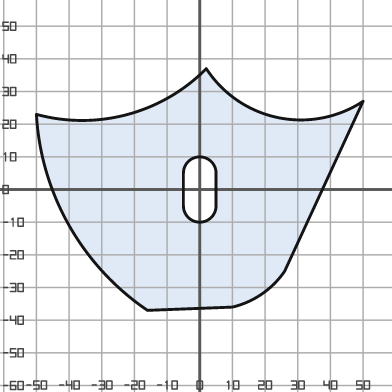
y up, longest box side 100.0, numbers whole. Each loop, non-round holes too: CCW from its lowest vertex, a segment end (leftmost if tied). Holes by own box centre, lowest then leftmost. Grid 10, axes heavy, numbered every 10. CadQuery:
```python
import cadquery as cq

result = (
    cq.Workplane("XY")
    .moveTo(-16.0, -37.0)
    .lineTo(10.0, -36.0)
    .threePointArc((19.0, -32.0), (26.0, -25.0))
    .lineTo(50.0, 27.0)
    .threePointArc((24.0, 22.0), (2.0, 37.0))
    .threePointArc((-22.0, 23.0), (-50.0, 23.0))
    .threePointArc((-40.0, -11.0), (-16.0, -37.0))
    .close()
    .moveTo(-5.0, -5.0)
    .threePointArc((0.0, -10.0), (5.0, -5.0))
    .lineTo(5.0, 5.0)
    .threePointArc((0.0, 10.0), (-5.0, 5.0))
    .close()
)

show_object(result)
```